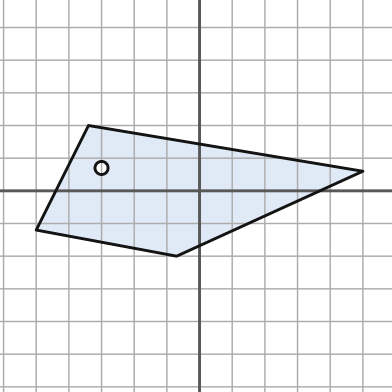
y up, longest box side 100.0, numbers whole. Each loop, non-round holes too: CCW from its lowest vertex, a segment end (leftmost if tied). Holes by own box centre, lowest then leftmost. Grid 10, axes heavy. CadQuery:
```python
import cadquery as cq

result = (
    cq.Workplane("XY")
    .moveTo(-7.0, -20.0)
    .lineTo(50.0, 6.0)
    .lineTo(-34.0, 20.0)
    .lineTo(-50.0, -12.0)
    .close()
    .moveTo(-30.0, 7.0)
    .circle(2.0)
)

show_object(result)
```